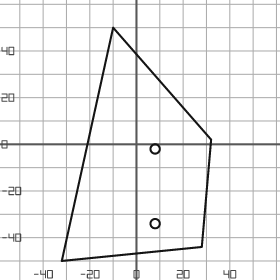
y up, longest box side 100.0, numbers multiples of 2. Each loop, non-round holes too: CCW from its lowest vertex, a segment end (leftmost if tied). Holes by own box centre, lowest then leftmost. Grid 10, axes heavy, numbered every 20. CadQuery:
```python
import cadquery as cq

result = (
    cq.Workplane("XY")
    .moveTo(-32.0, -50.0)
    .lineTo(28.0, -44.0)
    .lineTo(32.0, 2.0)
    .lineTo(-10.0, 50.0)
    .close()
    .moveTo(8.0, -34.0)
    .circle(2.0)
    .moveTo(8.0, -2.0)
    .circle(2.0)
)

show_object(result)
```